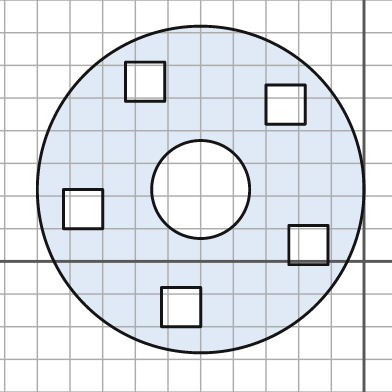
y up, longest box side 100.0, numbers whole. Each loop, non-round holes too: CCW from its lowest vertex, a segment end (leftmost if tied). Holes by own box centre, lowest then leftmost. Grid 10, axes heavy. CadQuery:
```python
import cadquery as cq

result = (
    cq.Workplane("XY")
    .moveTo(-50.0, 22.0)
    .circle(50.0)
    .moveTo(-62.0, -20.0)
    .lineTo(-50.0, -20.0)
    .lineTo(-50.0, -8.0)
    .lineTo(-62.0, -8.0)
    .close()
    .moveTo(-23.0, -1.0)
    .lineTo(-11.0, -1.0)
    .lineTo(-11.0, 11.0)
    .lineTo(-23.0, 11.0)
    .close()
    .moveTo(-92.0, 10.0)
    .lineTo(-80.0, 10.0)
    .lineTo(-80.0, 22.0)
    .lineTo(-92.0, 22.0)
    .close()
    .moveTo(-50.0, 22.0)
    .circle(15.0)
    .moveTo(-30.0, 42.0)
    .lineTo(-18.0, 42.0)
    .lineTo(-18.0, 54.0)
    .lineTo(-30.0, 54.0)
    .close()
    .moveTo(-73.0, 49.0)
    .lineTo(-61.0, 49.0)
    .lineTo(-61.0, 61.0)
    .lineTo(-73.0, 61.0)
    .close()
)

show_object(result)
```